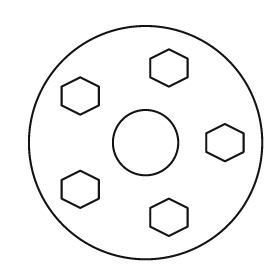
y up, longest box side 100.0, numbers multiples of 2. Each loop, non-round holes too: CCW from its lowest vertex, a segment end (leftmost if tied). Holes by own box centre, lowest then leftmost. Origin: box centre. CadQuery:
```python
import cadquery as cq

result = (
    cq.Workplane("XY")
    .moveTo(0.0, 0.0)
    .circle(50.0)
    .moveTo(10.0, -40.0)
    .lineTo(18.0, -36.0)
    .lineTo(18.0, -28.0)
    .lineTo(10.0, -24.0)
    .lineTo(2.0, -28.0)
    .lineTo(2.0, -36.0)
    .close()
    .moveTo(-28.0, -28.0)
    .lineTo(-20.0, -24.0)
    .lineTo(-20.0, -16.0)
    .lineTo(-28.0, -12.0)
    .lineTo(-36.0, -16.0)
    .lineTo(-36.0, -24.0)
    .close()
    .moveTo(0.0, 0.0)
    .circle(14.0)
    .moveTo(34.0, -8.0)
    .lineTo(42.0, -4.0)
    .lineTo(42.0, 4.0)
    .lineTo(34.0, 8.0)
    .lineTo(26.0, 4.0)
    .lineTo(26.0, -4.0)
    .close()
    .moveTo(-28.0, 12.0)
    .lineTo(-20.0, 16.0)
    .lineTo(-20.0, 24.0)
    .lineTo(-28.0, 28.0)
    .lineTo(-36.0, 24.0)
    .lineTo(-36.0, 16.0)
    .close()
    .moveTo(10.0, 24.0)
    .lineTo(18.0, 28.0)
    .lineTo(18.0, 36.0)
    .lineTo(10.0, 40.0)
    .lineTo(2.0, 36.0)
    .lineTo(2.0, 28.0)
    .close()
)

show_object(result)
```